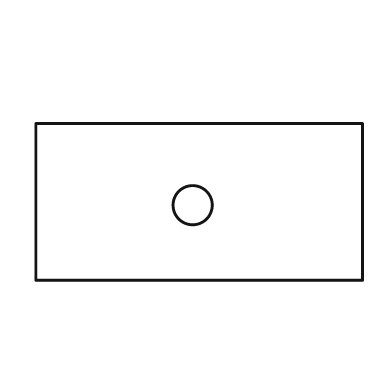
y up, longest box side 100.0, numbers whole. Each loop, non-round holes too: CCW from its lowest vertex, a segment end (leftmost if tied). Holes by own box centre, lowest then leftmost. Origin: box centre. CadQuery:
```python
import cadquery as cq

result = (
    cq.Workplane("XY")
    .moveTo(-50.0, -24.0)
    .lineTo(50.0, -24.0)
    .lineTo(50.0, 24.0)
    .lineTo(-50.0, 24.0)
    .close()
    .moveTo(-2.0, -1.0)
    .circle(6.0)
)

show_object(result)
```